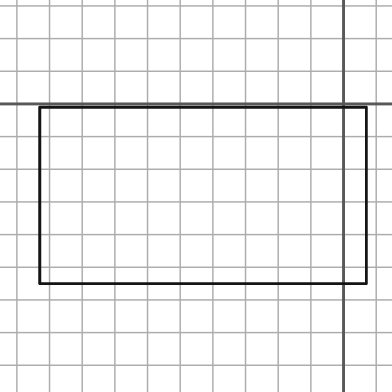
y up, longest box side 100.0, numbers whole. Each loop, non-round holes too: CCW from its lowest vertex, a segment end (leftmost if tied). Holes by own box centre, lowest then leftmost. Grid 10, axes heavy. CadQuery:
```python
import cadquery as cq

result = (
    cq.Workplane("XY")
    .moveTo(-93.0, -55.0)
    .lineTo(7.0, -55.0)
    .lineTo(7.0, -1.0)
    .lineTo(-93.0, -1.0)
    .close()
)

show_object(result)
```